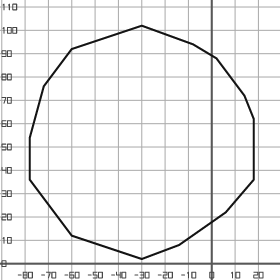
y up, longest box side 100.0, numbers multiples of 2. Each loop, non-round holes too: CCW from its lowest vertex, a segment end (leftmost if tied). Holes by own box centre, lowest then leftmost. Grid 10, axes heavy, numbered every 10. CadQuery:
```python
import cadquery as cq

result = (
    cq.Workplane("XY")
    .moveTo(-30.0, 2.0)
    .lineTo(-14.0, 8.0)
    .lineTo(6.0, 22.0)
    .lineTo(18.0, 36.0)
    .lineTo(18.0, 62.0)
    .lineTo(14.0, 72.0)
    .lineTo(2.0, 88.0)
    .lineTo(-8.0, 94.0)
    .lineTo(-30.0, 102.0)
    .lineTo(-60.0, 92.0)
    .lineTo(-72.0, 76.0)
    .lineTo(-78.0, 54.0)
    .lineTo(-78.0, 36.0)
    .lineTo(-60.0, 12.0)
    .close()
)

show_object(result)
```